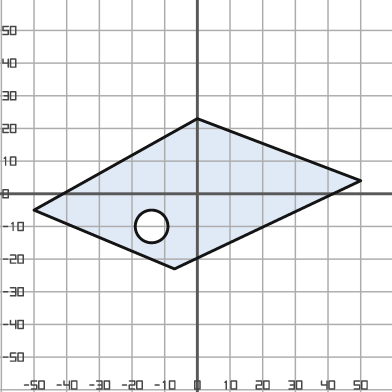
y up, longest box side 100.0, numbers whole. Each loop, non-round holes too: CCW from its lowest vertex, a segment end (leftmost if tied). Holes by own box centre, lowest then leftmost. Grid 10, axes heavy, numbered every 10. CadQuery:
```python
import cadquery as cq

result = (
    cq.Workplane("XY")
    .moveTo(-7.0, -23.0)
    .lineTo(50.0, 4.0)
    .lineTo(0.0, 23.0)
    .lineTo(-50.0, -5.0)
    .close()
    .moveTo(-14.0, -10.0)
    .circle(5.0)
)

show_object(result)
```